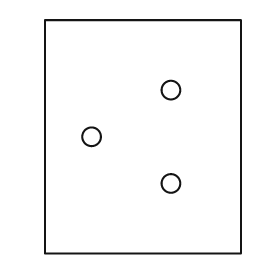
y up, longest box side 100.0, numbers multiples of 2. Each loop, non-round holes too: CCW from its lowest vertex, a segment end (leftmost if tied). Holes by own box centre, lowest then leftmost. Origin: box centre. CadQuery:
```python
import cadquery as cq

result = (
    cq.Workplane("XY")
    .moveTo(-42.0, -50.0)
    .lineTo(42.0, -50.0)
    .lineTo(42.0, 50.0)
    .lineTo(-42.0, 50.0)
    .close()
    .moveTo(12.0, -20.0)
    .circle(4.0)
    .moveTo(-22.0, 0.0)
    .circle(4.0)
    .moveTo(12.0, 20.0)
    .circle(4.0)
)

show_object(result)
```